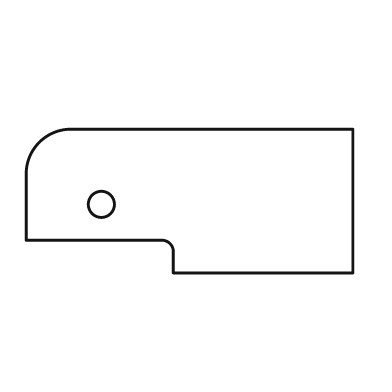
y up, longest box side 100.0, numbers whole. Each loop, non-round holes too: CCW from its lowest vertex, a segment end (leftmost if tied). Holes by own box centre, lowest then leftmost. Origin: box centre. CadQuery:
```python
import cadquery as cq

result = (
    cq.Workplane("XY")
    .moveTo(-5.0, -22.0)
    .lineTo(50.0, -22.0)
    .lineTo(50.0, 22.0)
    .lineTo(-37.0, 22.0)
    .threePointArc((-46.0, 18.0), (-50.0, 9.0))
    .lineTo(-50.0, -12.0)
    .lineTo(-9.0, -12.0)
    .threePointArc((-6.0, -13.0), (-5.0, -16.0))
    .close()
    .moveTo(-27.0, -1.0)
    .circle(4.0)
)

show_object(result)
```